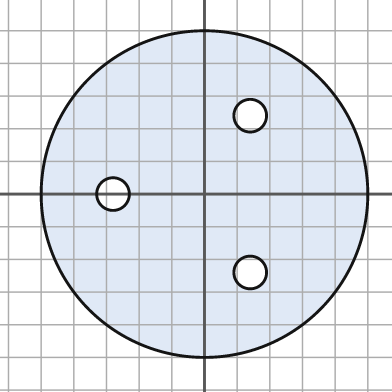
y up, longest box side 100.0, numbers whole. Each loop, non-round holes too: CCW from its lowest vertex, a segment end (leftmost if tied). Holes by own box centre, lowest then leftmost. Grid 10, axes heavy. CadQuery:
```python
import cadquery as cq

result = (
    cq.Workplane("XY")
    .moveTo(0.0, 0.0)
    .circle(50.0)
    .moveTo(14.0, -24.0)
    .circle(5.0)
    .moveTo(-28.0, 0.0)
    .circle(5.0)
    .moveTo(14.0, 24.0)
    .circle(5.0)
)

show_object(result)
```